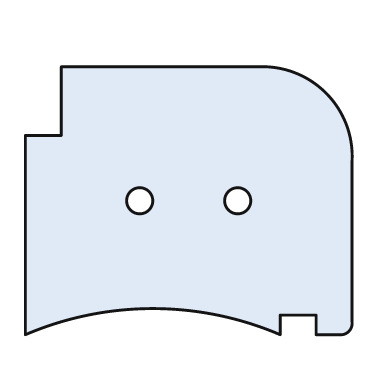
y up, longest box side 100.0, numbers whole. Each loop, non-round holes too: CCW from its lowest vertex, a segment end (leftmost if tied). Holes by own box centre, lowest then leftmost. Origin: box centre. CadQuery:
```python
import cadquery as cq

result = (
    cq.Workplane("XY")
    .moveTo(-50.0, -41.0)
    .threePointArc((-11.0, -33.0), (28.0, -41.0))
    .lineTo(28.0, -35.0)
    .lineTo(39.0, -35.0)
    .lineTo(39.0, -41.0)
    .lineTo(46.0, -41.0)
    .threePointArc((49.0, -40.0), (50.0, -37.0))
    .lineTo(50.0, 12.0)
    .threePointArc((42.0, 33.0), (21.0, 41.0))
    .lineTo(-39.0, 41.0)
    .lineTo(-39.0, 20.0)
    .lineTo(-50.0, 20.0)
    .close()
    .moveTo(-15.0, 0.0)
    .circle(4.0)
    .moveTo(15.0, 0.0)
    .circle(4.0)
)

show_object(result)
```